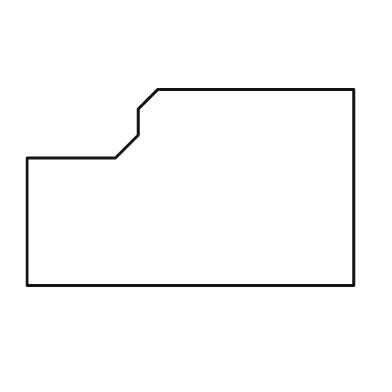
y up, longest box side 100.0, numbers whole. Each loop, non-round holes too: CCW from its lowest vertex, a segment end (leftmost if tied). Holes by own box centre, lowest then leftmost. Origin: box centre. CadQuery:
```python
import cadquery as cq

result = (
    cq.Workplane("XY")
    .moveTo(-50.0, -30.0)
    .lineTo(50.0, -30.0)
    .lineTo(50.0, 30.0)
    .lineTo(-10.0, 30.0)
    .lineTo(-16.0, 24.0)
    .lineTo(-16.0, 16.0)
    .lineTo(-23.0, 9.0)
    .lineTo(-50.0, 9.0)
    .close()
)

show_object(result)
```